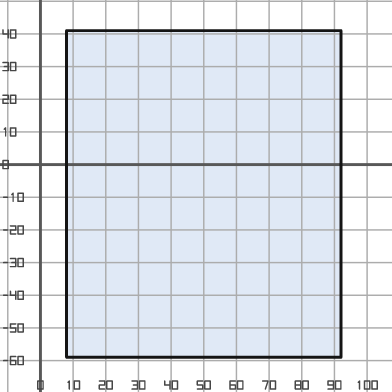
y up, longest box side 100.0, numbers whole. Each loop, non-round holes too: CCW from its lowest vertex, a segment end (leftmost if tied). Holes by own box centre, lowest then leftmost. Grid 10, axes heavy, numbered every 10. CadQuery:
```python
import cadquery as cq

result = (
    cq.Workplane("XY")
    .moveTo(8.0, -59.0)
    .lineTo(92.0, -59.0)
    .lineTo(92.0, 41.0)
    .lineTo(8.0, 41.0)
    .close()
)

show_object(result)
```